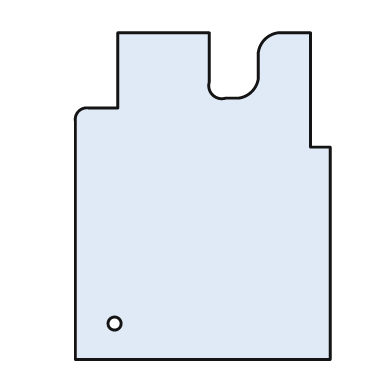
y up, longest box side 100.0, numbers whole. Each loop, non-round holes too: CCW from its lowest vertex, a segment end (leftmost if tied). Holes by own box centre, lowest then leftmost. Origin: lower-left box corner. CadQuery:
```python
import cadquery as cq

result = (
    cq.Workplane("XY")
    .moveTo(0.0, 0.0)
    .lineTo(78.0, 0.0)
    .lineTo(78.0, 65.0)
    .lineTo(72.0, 65.0)
    .lineTo(72.0, 100.0)
    .lineTo(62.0, 100.0)
    .threePointArc((58.0, 98.0), (56.0, 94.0))
    .lineTo(56.0, 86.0)
    .threePointArc((54.0, 82.0), (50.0, 80.0))
    .lineTo(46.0, 80.0)
    .threePointArc((42.0, 81.0), (41.0, 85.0))
    .lineTo(41.0, 100.0)
    .lineTo(13.0, 100.0)
    .lineTo(13.0, 77.0)
    .lineTo(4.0, 77.0)
    .threePointArc((1.0, 76.0), (0.0, 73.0))
    .close()
    .moveTo(12.0, 11.0)
    .circle(2.0)
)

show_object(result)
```